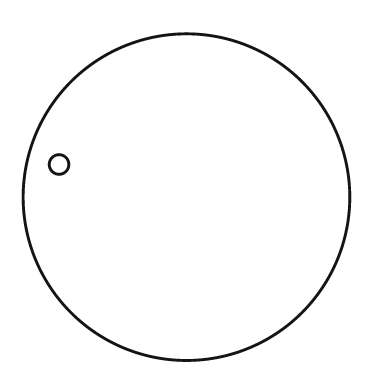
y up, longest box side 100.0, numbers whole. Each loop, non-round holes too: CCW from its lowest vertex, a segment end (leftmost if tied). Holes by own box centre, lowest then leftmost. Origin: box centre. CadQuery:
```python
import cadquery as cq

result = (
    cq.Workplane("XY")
    .moveTo(0.0, 0.0)
    .circle(50.0)
    .moveTo(-39.0, 10.0)
    .circle(3.0)
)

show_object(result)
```